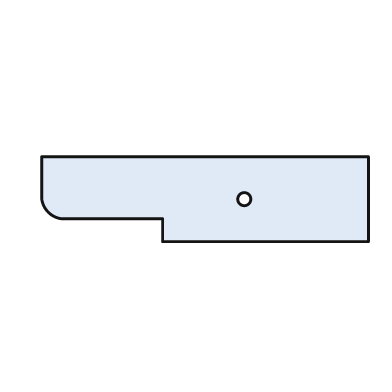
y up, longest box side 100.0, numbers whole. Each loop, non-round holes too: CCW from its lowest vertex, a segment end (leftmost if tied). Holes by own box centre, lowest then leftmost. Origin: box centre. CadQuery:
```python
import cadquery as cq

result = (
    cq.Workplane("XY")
    .moveTo(-13.0, -13.0)
    .lineTo(50.0, -13.0)
    .lineTo(50.0, 13.0)
    .lineTo(-50.0, 13.0)
    .lineTo(-50.0, 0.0)
    .threePointArc((-48.0, -4.0), (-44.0, -6.0))
    .lineTo(-13.0, -6.0)
    .close()
    .moveTo(12.0, 0.0)
    .circle(2.0)
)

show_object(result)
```